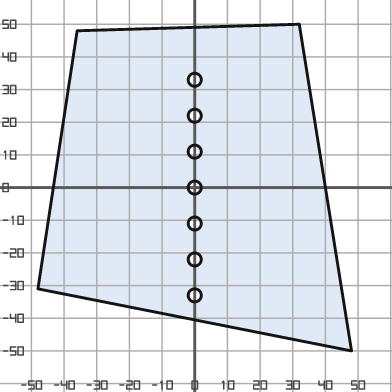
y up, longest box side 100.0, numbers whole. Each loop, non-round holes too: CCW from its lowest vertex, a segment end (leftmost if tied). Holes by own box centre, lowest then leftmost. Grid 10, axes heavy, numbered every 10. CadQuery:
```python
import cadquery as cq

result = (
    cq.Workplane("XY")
    .moveTo(48.0, -50.0)
    .lineTo(32.0, 50.0)
    .lineTo(-36.0, 48.0)
    .lineTo(-48.0, -31.0)
    .close()
    .moveTo(0.0, -33.0)
    .circle(2.0)
    .moveTo(0.0, -22.0)
    .circle(2.0)
    .moveTo(0.0, -11.0)
    .circle(2.0)
    .moveTo(0.0, 0.0)
    .circle(2.0)
    .moveTo(0.0, 11.0)
    .circle(2.0)
    .moveTo(0.0, 22.0)
    .circle(2.0)
    .moveTo(0.0, 33.0)
    .circle(2.0)
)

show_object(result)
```